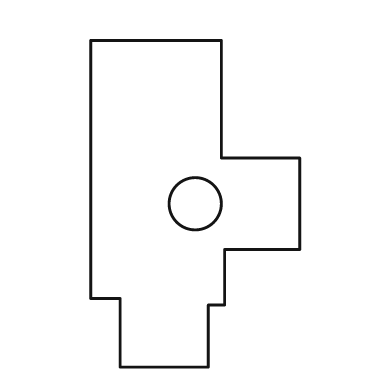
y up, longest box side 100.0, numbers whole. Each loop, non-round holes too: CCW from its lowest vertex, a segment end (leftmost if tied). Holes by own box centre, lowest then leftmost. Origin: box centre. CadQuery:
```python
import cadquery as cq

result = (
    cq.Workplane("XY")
    .moveTo(-23.0, -50.0)
    .lineTo(4.0, -50.0)
    .lineTo(4.0, -31.0)
    .lineTo(9.0, -31.0)
    .lineTo(9.0, -14.0)
    .lineTo(32.0, -14.0)
    .lineTo(32.0, 14.0)
    .lineTo(8.0, 14.0)
    .lineTo(8.0, 50.0)
    .lineTo(-32.0, 50.0)
    .lineTo(-32.0, -29.0)
    .lineTo(-23.0, -29.0)
    .close()
    .moveTo(0.0, 0.0)
    .circle(8.0)
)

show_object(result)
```